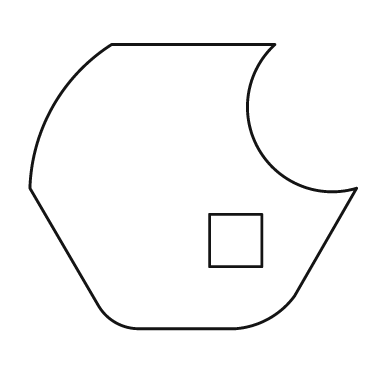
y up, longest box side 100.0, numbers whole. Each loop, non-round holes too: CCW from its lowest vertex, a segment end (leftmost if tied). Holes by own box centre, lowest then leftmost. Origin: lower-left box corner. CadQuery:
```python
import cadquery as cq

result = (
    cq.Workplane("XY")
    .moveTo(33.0, 0.0)
    .lineTo(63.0, 0.0)
    .threePointArc((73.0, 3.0), (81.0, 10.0))
    .lineTo(100.0, 43.0)
    .threePointArc((70.0, 55.0), (75.0, 87.0))
    .lineTo(25.0, 87.0)
    .threePointArc((7.0, 68.0), (0.0, 43.0))
    .lineTo(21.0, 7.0)
    .threePointArc((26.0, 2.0), (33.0, 0.0))
    .close()
    .moveTo(55.0, 19.0)
    .lineTo(71.0, 19.0)
    .lineTo(71.0, 35.0)
    .lineTo(55.0, 35.0)
    .close()
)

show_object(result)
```